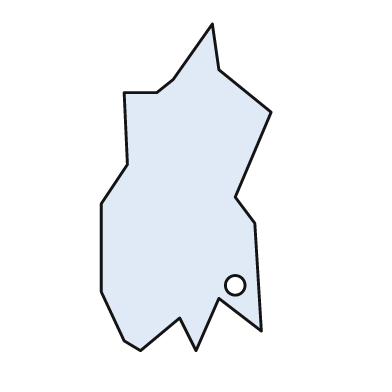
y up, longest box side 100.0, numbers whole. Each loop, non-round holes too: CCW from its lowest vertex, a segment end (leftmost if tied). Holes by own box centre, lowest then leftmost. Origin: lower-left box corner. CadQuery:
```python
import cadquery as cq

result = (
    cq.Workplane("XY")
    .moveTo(12.0, 0.0)
    .lineTo(24.0, 10.0)
    .lineTo(29.0, 0.0)
    .lineTo(36.0, 16.0)
    .lineTo(49.0, 6.0)
    .lineTo(47.0, 39.0)
    .lineTo(41.0, 47.0)
    .lineTo(52.0, 73.0)
    .lineTo(36.0, 86.0)
    .lineTo(34.0, 100.0)
    .lineTo(22.0, 83.0)
    .lineTo(17.0, 79.0)
    .lineTo(7.0, 79.0)
    .lineTo(8.0, 57.0)
    .lineTo(0.0, 45.0)
    .lineTo(0.0, 18.0)
    .lineTo(7.0, 3.0)
    .close()
    .moveTo(41.0, 20.0)
    .circle(3.0)
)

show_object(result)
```